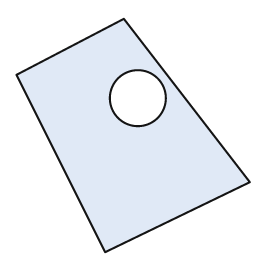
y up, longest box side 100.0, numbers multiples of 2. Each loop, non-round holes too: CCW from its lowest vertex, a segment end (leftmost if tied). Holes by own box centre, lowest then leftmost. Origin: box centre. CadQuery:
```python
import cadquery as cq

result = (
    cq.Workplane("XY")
    .moveTo(-12.0, -50.0)
    .lineTo(50.0, -20.0)
    .lineTo(-4.0, 50.0)
    .lineTo(-50.0, 26.0)
    .close()
    .moveTo(2.0, 16.0)
    .circle(12.0)
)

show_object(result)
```